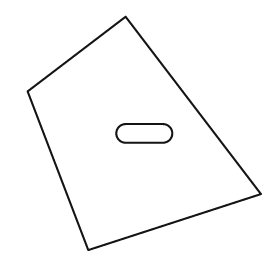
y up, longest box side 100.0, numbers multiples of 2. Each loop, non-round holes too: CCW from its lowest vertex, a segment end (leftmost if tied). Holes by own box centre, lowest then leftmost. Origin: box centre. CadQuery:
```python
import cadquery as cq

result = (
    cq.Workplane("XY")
    .moveTo(-24.0, -50.0)
    .lineTo(50.0, -26.0)
    .lineTo(-8.0, 50.0)
    .lineTo(-50.0, 18.0)
    .close()
    .moveTo(-8.0, -4.0)
    .lineTo(8.0, -4.0)
    .threePointArc((12.0, 0.0), (8.0, 4.0))
    .lineTo(-8.0, 4.0)
    .threePointArc((-12.0, 0.0), (-8.0, -4.0))
    .close()
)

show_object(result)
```